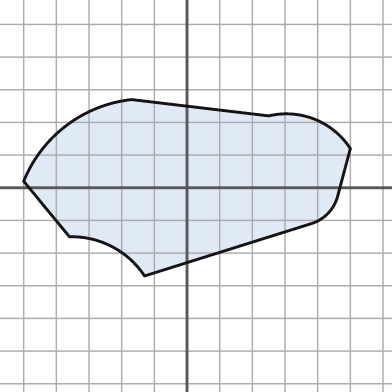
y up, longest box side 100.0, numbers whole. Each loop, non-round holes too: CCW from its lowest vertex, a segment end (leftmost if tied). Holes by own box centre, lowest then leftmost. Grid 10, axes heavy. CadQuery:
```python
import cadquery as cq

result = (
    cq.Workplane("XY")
    .moveTo(-13.0, -27.0)
    .lineTo(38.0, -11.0)
    .threePointArc((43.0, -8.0), (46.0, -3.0))
    .lineTo(50.0, 12.0)
    .threePointArc((39.0, 21.0), (25.0, 22.0))
    .lineTo(-17.0, 27.0)
    .threePointArc((-37.0, 19.0), (-50.0, 2.0))
    .lineTo(-36.0, -15.0)
    .threePointArc((-23.0, -18.0), (-13.0, -27.0))
    .close()
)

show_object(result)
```